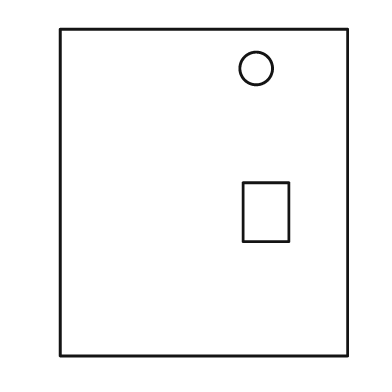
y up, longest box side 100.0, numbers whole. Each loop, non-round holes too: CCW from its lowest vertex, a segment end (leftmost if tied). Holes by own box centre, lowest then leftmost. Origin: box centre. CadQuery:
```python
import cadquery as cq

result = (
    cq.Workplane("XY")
    .moveTo(-44.0, -50.0)
    .lineTo(44.0, -50.0)
    .lineTo(44.0, 50.0)
    .lineTo(-44.0, 50.0)
    .close()
    .moveTo(12.0, -15.0)
    .lineTo(26.0, -15.0)
    .lineTo(26.0, 3.0)
    .lineTo(12.0, 3.0)
    .close()
    .moveTo(16.0, 38.0)
    .circle(5.0)
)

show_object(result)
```